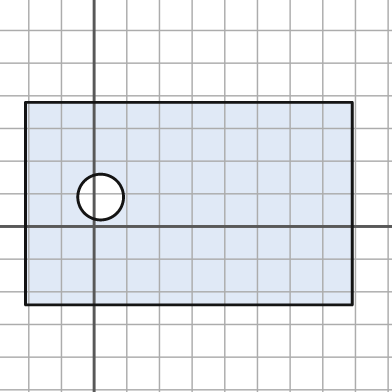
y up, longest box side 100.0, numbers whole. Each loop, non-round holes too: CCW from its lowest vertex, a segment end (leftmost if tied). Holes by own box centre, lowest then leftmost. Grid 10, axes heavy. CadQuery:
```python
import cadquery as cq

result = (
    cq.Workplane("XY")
    .moveTo(-21.0, -24.0)
    .lineTo(79.0, -24.0)
    .lineTo(79.0, 38.0)
    .lineTo(-21.0, 38.0)
    .close()
    .moveTo(2.0, 9.0)
    .circle(7.0)
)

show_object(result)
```